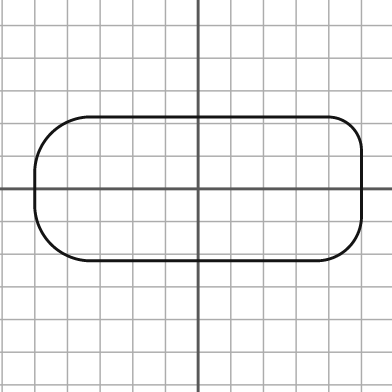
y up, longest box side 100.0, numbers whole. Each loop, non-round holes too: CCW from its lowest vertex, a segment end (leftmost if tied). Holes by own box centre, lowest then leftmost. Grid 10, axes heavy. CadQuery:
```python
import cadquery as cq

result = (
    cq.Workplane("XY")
    .moveTo(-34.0, -22.0)
    .lineTo(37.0, -22.0)
    .threePointArc((46.0, -18.0), (50.0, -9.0))
    .lineTo(50.0, 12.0)
    .threePointArc((47.0, 19.0), (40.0, 22.0))
    .lineTo(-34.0, 22.0)
    .threePointArc((-45.0, 17.0), (-50.0, 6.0))
    .lineTo(-50.0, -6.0)
    .threePointArc((-45.0, -17.0), (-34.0, -22.0))
    .close()
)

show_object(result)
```